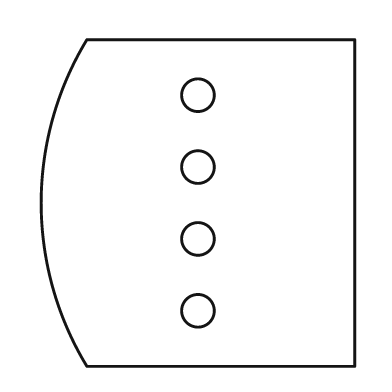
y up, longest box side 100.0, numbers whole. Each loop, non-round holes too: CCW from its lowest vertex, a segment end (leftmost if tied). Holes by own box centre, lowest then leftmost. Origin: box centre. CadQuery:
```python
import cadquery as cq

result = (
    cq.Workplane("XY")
    .moveTo(-34.0, -50.0)
    .lineTo(48.0, -50.0)
    .lineTo(48.0, 50.0)
    .lineTo(-34.0, 50.0)
    .threePointArc((-48.0, 0.0), (-34.0, -50.0))
    .close()
    .moveTo(0.0, -33.0)
    .circle(5.0)
    .moveTo(0.0, -11.0)
    .circle(5.0)
    .moveTo(0.0, 11.0)
    .circle(5.0)
    .moveTo(0.0, 33.0)
    .circle(5.0)
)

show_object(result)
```